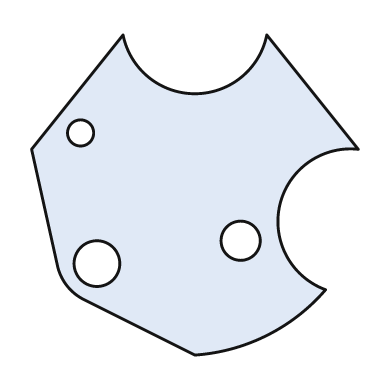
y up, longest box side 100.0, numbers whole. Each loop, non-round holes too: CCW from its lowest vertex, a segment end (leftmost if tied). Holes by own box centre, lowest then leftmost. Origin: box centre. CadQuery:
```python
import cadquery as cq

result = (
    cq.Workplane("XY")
    .moveTo(0.0, -49.0)
    .threePointArc((22.0, -43.0), (40.0, -29.0))
    .threePointArc((26.0, -3.0), (50.0, 14.0))
    .lineTo(22.0, 49.0)
    .threePointArc((0.0, 31.0), (-22.0, 49.0))
    .lineTo(-50.0, 14.0)
    .lineTo(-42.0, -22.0)
    .threePointArc((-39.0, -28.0), (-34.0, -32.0))
    .close()
    .moveTo(-30.0, -21.0)
    .circle(7.0)
    .moveTo(14.0, -14.0)
    .circle(6.0)
    .moveTo(-35.0, 19.0)
    .circle(4.0)
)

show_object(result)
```